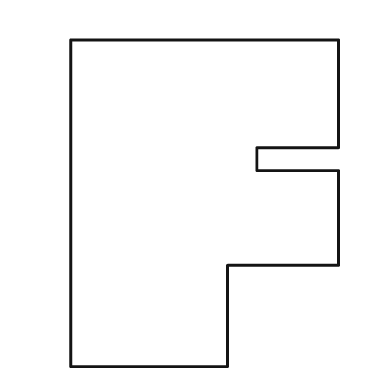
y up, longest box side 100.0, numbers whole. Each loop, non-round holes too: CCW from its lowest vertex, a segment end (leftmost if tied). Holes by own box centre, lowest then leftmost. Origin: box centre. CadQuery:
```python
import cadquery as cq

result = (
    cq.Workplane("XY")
    .moveTo(-41.0, -50.0)
    .lineTo(7.0, -50.0)
    .lineTo(7.0, -19.0)
    .lineTo(41.0, -19.0)
    .lineTo(41.0, 10.0)
    .lineTo(16.0, 10.0)
    .lineTo(16.0, 17.0)
    .lineTo(41.0, 17.0)
    .lineTo(41.0, 50.0)
    .lineTo(-41.0, 50.0)
    .close()
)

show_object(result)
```